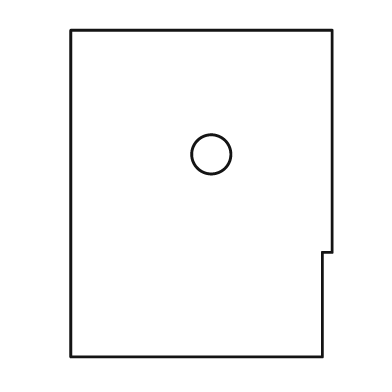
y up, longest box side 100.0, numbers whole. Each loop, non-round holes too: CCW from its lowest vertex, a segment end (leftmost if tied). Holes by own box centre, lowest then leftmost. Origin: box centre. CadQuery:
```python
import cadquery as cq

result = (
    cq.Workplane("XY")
    .moveTo(-40.0, -50.0)
    .lineTo(37.0, -50.0)
    .lineTo(37.0, -18.0)
    .lineTo(40.0, -18.0)
    .lineTo(40.0, 50.0)
    .lineTo(-40.0, 50.0)
    .close()
    .moveTo(3.0, 12.0)
    .circle(6.0)
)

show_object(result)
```